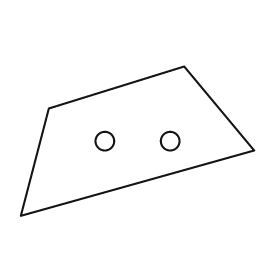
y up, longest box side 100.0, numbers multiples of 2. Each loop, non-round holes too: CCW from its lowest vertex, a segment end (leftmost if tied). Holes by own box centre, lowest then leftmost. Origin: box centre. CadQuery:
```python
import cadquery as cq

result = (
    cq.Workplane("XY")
    .moveTo(-50.0, -32.0)
    .lineTo(50.0, -4.0)
    .lineTo(20.0, 32.0)
    .lineTo(-38.0, 14.0)
    .close()
    .moveTo(-14.0, 0.0)
    .circle(4.0)
    .moveTo(14.0, 0.0)
    .circle(4.0)
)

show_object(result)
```